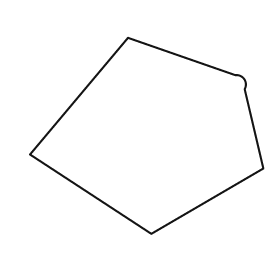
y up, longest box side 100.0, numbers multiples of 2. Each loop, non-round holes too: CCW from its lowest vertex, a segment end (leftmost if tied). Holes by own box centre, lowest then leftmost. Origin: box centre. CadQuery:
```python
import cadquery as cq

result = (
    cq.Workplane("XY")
    .moveTo(2.0, -42.0)
    .lineTo(50.0, -14.0)
    .lineTo(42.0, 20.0)
    .threePointArc((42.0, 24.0), (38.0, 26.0))
    .lineTo(-8.0, 42.0)
    .lineTo(-50.0, -8.0)
    .close()
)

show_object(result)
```